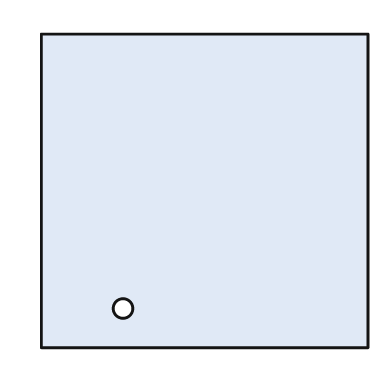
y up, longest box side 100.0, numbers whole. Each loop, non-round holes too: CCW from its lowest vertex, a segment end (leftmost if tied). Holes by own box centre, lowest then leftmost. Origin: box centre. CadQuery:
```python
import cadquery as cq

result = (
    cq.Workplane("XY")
    .moveTo(-50.0, -48.0)
    .lineTo(50.0, -48.0)
    .lineTo(50.0, 48.0)
    .lineTo(-50.0, 48.0)
    .close()
    .moveTo(-25.0, -36.0)
    .circle(3.0)
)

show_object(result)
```